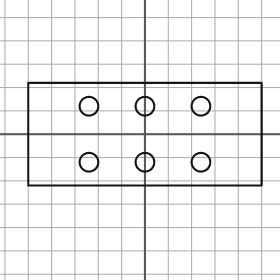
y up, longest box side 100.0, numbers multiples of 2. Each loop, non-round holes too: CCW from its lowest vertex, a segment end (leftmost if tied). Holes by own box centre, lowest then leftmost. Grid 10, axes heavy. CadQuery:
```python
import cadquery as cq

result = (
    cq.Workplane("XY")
    .moveTo(-50.0, -22.0)
    .lineTo(50.0, -22.0)
    .lineTo(50.0, 22.0)
    .lineTo(-50.0, 22.0)
    .close()
    .moveTo(-24.0, -12.0)
    .circle(4.0)
    .moveTo(0.0, -12.0)
    .circle(4.0)
    .moveTo(24.0, -12.0)
    .circle(4.0)
    .moveTo(-24.0, 12.0)
    .circle(4.0)
    .moveTo(0.0, 12.0)
    .circle(4.0)
    .moveTo(24.0, 12.0)
    .circle(4.0)
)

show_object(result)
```